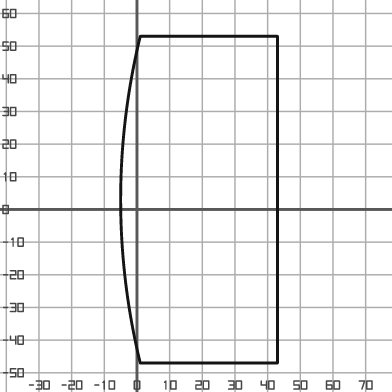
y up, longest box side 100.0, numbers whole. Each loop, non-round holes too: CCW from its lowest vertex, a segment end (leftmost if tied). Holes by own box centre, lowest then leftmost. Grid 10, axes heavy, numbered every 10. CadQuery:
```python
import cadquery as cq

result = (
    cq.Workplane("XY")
    .moveTo(1.0, -47.0)
    .lineTo(43.0, -47.0)
    .lineTo(43.0, 53.0)
    .lineTo(1.0, 53.0)
    .threePointArc((-5.0, 3.0), (1.0, -47.0))
    .close()
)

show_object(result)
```